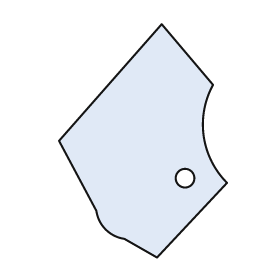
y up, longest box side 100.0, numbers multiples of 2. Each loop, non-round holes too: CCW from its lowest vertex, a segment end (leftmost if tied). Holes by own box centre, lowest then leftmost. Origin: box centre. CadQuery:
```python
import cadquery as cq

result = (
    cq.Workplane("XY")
    .moveTo(6.0, -50.0)
    .lineTo(36.0, -18.0)
    .threePointArc((26.0, 2.0), (30.0, 24.0))
    .lineTo(8.0, 50.0)
    .lineTo(-36.0, 0.0)
    .lineTo(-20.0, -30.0)
    .threePointArc((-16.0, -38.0), (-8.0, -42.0))
    .close()
    .moveTo(18.0, -16.0)
    .circle(4.0)
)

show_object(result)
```